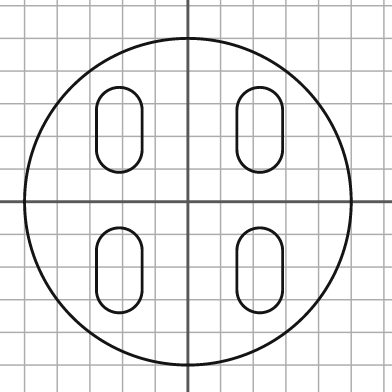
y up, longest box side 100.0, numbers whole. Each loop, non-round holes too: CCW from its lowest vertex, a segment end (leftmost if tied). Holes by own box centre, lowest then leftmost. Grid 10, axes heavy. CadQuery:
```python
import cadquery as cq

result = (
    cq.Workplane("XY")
    .moveTo(0.0, 0.0)
    .circle(50.0)
    .moveTo(-28.0, -27.0)
    .threePointArc((-21.0, -34.0), (-14.0, -27.0))
    .lineTo(-14.0, -15.0)
    .threePointArc((-21.0, -8.0), (-28.0, -15.0))
    .close()
    .moveTo(15.0, -27.0)
    .threePointArc((22.0, -34.0), (29.0, -27.0))
    .lineTo(29.0, -15.0)
    .threePointArc((22.0, -8.0), (15.0, -15.0))
    .close()
    .moveTo(-28.0, 16.0)
    .threePointArc((-21.0, 9.0), (-14.0, 16.0))
    .lineTo(-14.0, 28.0)
    .threePointArc((-21.0, 35.0), (-28.0, 28.0))
    .close()
    .moveTo(15.0, 16.0)
    .threePointArc((22.0, 9.0), (29.0, 16.0))
    .lineTo(29.0, 28.0)
    .threePointArc((22.0, 35.0), (15.0, 28.0))
    .close()
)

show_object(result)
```